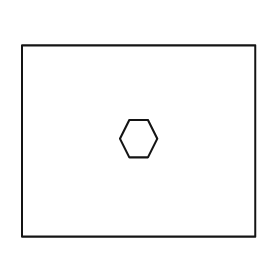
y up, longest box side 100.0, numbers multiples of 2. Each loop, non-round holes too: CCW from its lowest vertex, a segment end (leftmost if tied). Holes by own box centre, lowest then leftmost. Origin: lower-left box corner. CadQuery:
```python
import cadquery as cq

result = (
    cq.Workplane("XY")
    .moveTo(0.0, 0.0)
    .lineTo(100.0, 0.0)
    .lineTo(100.0, 82.0)
    .lineTo(0.0, 82.0)
    .close()
    .moveTo(46.0, 34.0)
    .lineTo(54.0, 34.0)
    .lineTo(58.0, 42.0)
    .lineTo(54.0, 50.0)
    .lineTo(46.0, 50.0)
    .lineTo(42.0, 42.0)
    .close()
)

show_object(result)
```